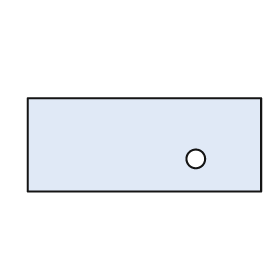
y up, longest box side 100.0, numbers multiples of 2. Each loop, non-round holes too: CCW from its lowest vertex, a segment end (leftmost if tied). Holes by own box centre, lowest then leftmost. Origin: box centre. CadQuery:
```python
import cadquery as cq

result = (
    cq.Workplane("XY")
    .moveTo(-50.0, -20.0)
    .lineTo(50.0, -20.0)
    .lineTo(50.0, 20.0)
    .lineTo(-50.0, 20.0)
    .close()
    .moveTo(22.0, -6.0)
    .circle(4.0)
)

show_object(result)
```